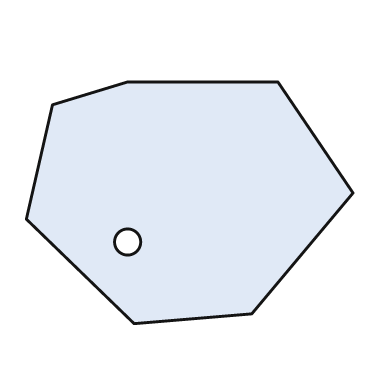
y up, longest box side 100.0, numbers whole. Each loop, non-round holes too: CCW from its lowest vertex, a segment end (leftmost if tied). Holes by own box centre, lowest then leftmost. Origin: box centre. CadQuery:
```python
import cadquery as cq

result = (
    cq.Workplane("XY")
    .moveTo(-17.0, -37.0)
    .lineTo(19.0, -34.0)
    .lineTo(50.0, 3.0)
    .lineTo(27.0, 37.0)
    .lineTo(-19.0, 37.0)
    .lineTo(-42.0, 30.0)
    .lineTo(-50.0, -5.0)
    .close()
    .moveTo(-19.0, -12.0)
    .circle(4.0)
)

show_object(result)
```